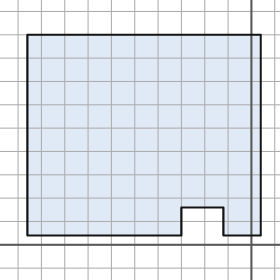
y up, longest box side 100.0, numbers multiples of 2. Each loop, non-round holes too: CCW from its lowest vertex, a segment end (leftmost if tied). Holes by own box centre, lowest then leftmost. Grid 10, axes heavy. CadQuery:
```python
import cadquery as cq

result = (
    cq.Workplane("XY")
    .moveTo(-96.0, 4.0)
    .lineTo(-30.0, 4.0)
    .lineTo(-30.0, 16.0)
    .lineTo(-12.0, 16.0)
    .lineTo(-12.0, 4.0)
    .lineTo(4.0, 4.0)
    .lineTo(4.0, 90.0)
    .lineTo(-96.0, 90.0)
    .close()
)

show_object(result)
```